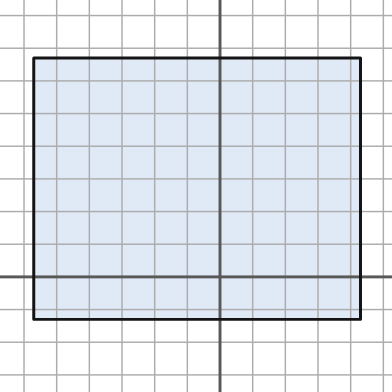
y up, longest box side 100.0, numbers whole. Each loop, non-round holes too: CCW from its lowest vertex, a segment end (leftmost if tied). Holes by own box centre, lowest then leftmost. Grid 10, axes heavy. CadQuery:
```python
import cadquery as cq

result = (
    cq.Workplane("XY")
    .moveTo(-57.0, -13.0)
    .lineTo(43.0, -13.0)
    .lineTo(43.0, 67.0)
    .lineTo(-57.0, 67.0)
    .close()
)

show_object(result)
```